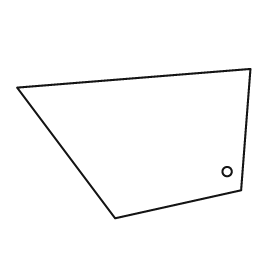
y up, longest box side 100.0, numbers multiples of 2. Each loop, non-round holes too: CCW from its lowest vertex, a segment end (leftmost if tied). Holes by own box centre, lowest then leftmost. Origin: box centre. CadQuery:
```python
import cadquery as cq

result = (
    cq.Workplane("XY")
    .moveTo(-8.0, -32.0)
    .lineTo(46.0, -20.0)
    .lineTo(50.0, 32.0)
    .lineTo(-50.0, 24.0)
    .close()
    .moveTo(40.0, -12.0)
    .circle(2.0)
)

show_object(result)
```